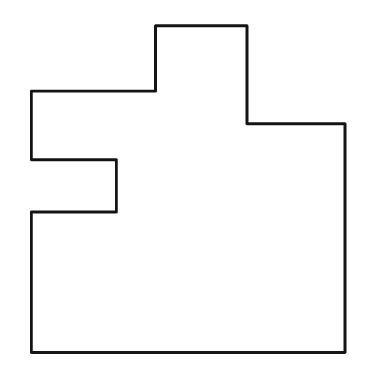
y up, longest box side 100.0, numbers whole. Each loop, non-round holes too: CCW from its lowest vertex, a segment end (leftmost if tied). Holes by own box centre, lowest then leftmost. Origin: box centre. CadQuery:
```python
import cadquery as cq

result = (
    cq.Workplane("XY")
    .moveTo(-48.0, -50.0)
    .lineTo(48.0, -50.0)
    .lineTo(48.0, 20.0)
    .lineTo(18.0, 20.0)
    .lineTo(18.0, 50.0)
    .lineTo(-10.0, 50.0)
    .lineTo(-10.0, 30.0)
    .lineTo(-48.0, 30.0)
    .lineTo(-48.0, 9.0)
    .lineTo(-22.0, 9.0)
    .lineTo(-22.0, -7.0)
    .lineTo(-48.0, -7.0)
    .close()
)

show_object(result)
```